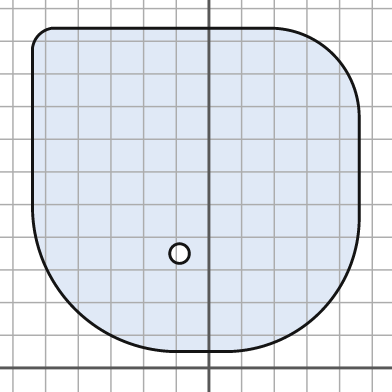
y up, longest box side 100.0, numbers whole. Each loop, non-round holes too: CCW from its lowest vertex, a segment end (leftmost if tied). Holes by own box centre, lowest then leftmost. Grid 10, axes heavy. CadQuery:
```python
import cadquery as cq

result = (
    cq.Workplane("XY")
    .moveTo(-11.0, 5.0)
    .lineTo(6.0, 5.0)
    .threePointArc((34.0, 17.0), (46.0, 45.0))
    .lineTo(46.0, 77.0)
    .threePointArc((38.0, 96.0), (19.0, 104.0))
    .lineTo(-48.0, 104.0)
    .threePointArc((-52.0, 102.0), (-54.0, 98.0))
    .lineTo(-54.0, 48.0)
    .threePointArc((-41.0, 18.0), (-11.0, 5.0))
    .close()
    .moveTo(-9.0, 35.0)
    .circle(3.0)
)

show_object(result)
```